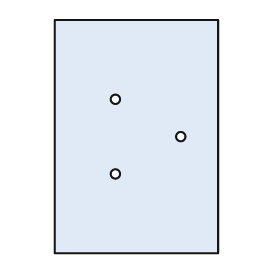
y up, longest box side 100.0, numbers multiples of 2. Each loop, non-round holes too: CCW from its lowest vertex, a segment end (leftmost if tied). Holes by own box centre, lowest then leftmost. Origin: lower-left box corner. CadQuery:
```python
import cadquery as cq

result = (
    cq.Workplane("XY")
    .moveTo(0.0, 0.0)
    .lineTo(70.0, 0.0)
    .lineTo(70.0, 100.0)
    .lineTo(0.0, 100.0)
    .close()
    .moveTo(26.0, 34.0)
    .circle(2.0)
    .moveTo(54.0, 50.0)
    .circle(2.0)
    .moveTo(26.0, 66.0)
    .circle(2.0)
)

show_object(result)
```